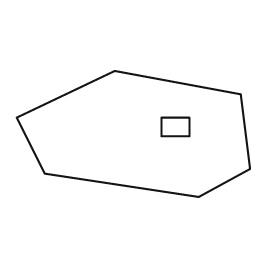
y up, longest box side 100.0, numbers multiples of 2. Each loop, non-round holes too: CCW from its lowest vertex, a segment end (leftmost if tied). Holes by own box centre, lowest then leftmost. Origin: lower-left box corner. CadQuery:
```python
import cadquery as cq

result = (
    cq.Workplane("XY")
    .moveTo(78.0, 0.0)
    .lineTo(100.0, 12.0)
    .lineTo(96.0, 44.0)
    .lineTo(42.0, 54.0)
    .lineTo(0.0, 34.0)
    .lineTo(12.0, 10.0)
    .close()
    .moveTo(62.0, 26.0)
    .lineTo(74.0, 26.0)
    .lineTo(74.0, 34.0)
    .lineTo(62.0, 34.0)
    .close()
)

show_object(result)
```